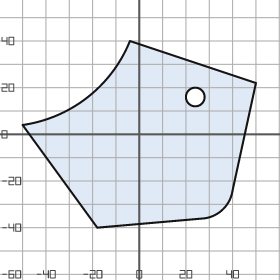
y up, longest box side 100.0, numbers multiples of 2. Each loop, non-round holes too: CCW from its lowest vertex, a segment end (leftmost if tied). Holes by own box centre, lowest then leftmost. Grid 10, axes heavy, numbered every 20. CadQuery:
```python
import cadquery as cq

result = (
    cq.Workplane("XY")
    .moveTo(-18.0, -40.0)
    .lineTo(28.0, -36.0)
    .threePointArc((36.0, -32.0), (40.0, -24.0))
    .lineTo(50.0, 22.0)
    .lineTo(-4.0, 40.0)
    .threePointArc((-22.0, 16.0), (-50.0, 4.0))
    .close()
    .moveTo(24.0, 16.0)
    .circle(4.0)
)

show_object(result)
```